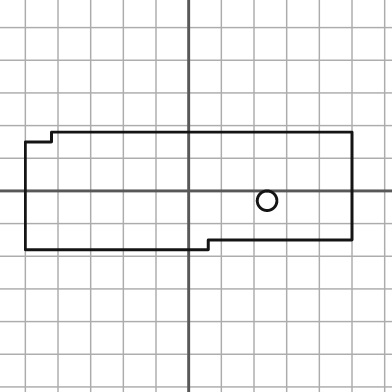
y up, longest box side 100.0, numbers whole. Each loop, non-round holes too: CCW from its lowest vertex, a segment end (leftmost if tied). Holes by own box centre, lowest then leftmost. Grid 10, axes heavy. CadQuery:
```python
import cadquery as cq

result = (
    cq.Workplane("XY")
    .moveTo(-50.0, -18.0)
    .lineTo(6.0, -18.0)
    .lineTo(6.0, -15.0)
    .lineTo(50.0, -15.0)
    .lineTo(50.0, 18.0)
    .lineTo(-42.0, 18.0)
    .lineTo(-42.0, 15.0)
    .lineTo(-50.0, 15.0)
    .close()
    .moveTo(24.0, -3.0)
    .circle(3.0)
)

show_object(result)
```